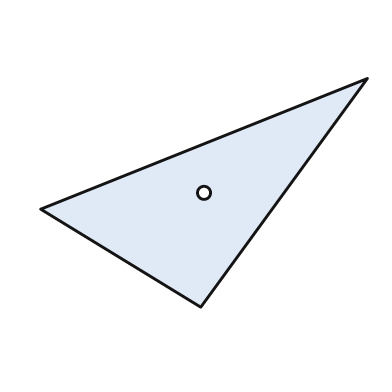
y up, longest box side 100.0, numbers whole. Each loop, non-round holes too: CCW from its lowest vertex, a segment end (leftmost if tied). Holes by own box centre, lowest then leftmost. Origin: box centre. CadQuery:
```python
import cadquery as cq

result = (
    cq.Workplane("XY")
    .moveTo(-1.0, -35.0)
    .lineTo(50.0, 35.0)
    .lineTo(-50.0, -5.0)
    .close()
    .moveTo(0.0, 0.0)
    .circle(2.0)
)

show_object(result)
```